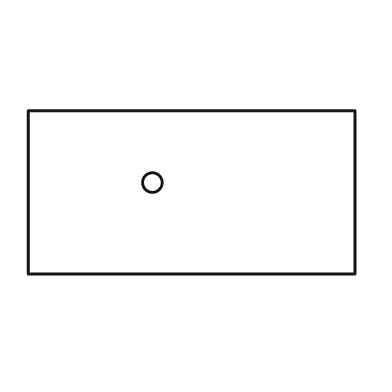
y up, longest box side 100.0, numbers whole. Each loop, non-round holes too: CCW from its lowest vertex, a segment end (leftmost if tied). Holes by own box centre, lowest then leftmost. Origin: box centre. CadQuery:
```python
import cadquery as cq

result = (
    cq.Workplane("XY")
    .moveTo(-50.0, -25.0)
    .lineTo(50.0, -25.0)
    .lineTo(50.0, 25.0)
    .lineTo(-50.0, 25.0)
    .close()
    .moveTo(-12.0, 3.0)
    .circle(3.0)
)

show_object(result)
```